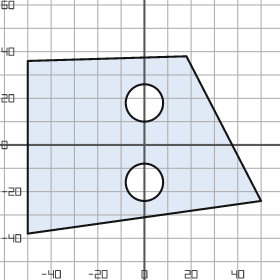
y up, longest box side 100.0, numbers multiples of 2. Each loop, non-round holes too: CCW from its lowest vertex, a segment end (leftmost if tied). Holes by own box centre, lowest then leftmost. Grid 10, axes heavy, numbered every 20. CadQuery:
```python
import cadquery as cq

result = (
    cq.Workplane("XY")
    .moveTo(-50.0, -38.0)
    .lineTo(50.0, -24.0)
    .lineTo(18.0, 38.0)
    .lineTo(-50.0, 36.0)
    .close()
    .moveTo(0.0, -16.0)
    .circle(8.0)
    .moveTo(0.0, 18.0)
    .circle(8.0)
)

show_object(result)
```